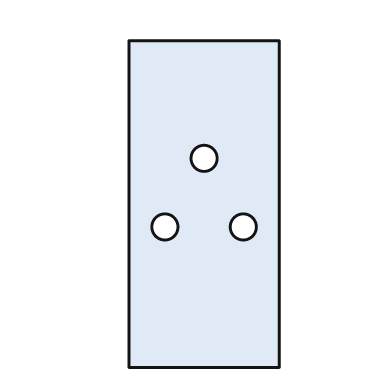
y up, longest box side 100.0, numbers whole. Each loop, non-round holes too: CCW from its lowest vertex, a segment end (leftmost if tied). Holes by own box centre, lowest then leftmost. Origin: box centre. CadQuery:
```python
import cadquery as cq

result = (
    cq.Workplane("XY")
    .moveTo(-23.0, -50.0)
    .lineTo(23.0, -50.0)
    .lineTo(23.0, 50.0)
    .lineTo(-23.0, 50.0)
    .close()
    .moveTo(-12.0, -7.0)
    .circle(4.0)
    .moveTo(12.0, -7.0)
    .circle(4.0)
    .moveTo(0.0, 14.0)
    .circle(4.0)
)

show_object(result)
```